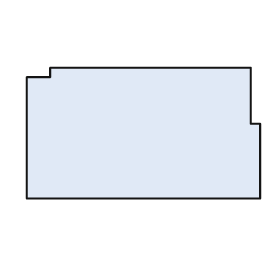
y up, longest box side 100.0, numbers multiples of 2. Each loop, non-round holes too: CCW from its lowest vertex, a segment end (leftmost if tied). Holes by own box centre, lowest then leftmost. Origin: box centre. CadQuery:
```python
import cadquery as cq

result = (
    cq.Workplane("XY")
    .moveTo(-50.0, -28.0)
    .lineTo(50.0, -28.0)
    .lineTo(50.0, 4.0)
    .lineTo(46.0, 4.0)
    .lineTo(46.0, 28.0)
    .lineTo(-40.0, 28.0)
    .lineTo(-40.0, 24.0)
    .lineTo(-50.0, 24.0)
    .close()
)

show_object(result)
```